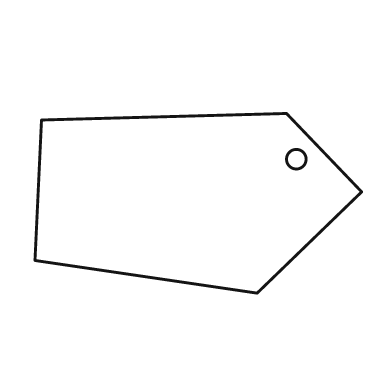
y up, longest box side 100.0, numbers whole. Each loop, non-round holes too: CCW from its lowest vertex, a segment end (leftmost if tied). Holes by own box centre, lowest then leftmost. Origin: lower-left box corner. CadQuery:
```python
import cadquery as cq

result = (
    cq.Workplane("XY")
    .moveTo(68.0, 0.0)
    .lineTo(100.0, 31.0)
    .lineTo(77.0, 55.0)
    .lineTo(2.0, 53.0)
    .lineTo(0.0, 10.0)
    .close()
    .moveTo(80.0, 41.0)
    .circle(3.0)
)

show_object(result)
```